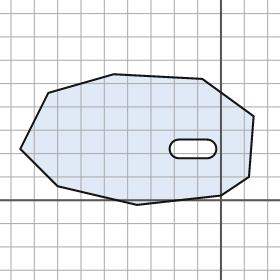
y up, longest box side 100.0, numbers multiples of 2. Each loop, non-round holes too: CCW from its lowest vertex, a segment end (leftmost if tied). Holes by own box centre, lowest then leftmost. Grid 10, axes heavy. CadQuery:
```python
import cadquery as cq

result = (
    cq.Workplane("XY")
    .moveTo(-36.0, -2.0)
    .lineTo(0.0, 2.0)
    .lineTo(12.0, 10.0)
    .lineTo(14.0, 36.0)
    .lineTo(-8.0, 52.0)
    .lineTo(-46.0, 54.0)
    .lineTo(-74.0, 46.0)
    .lineTo(-86.0, 22.0)
    .lineTo(-70.0, 6.0)
    .close()
    .moveTo(-18.0, 18.0)
    .lineTo(-6.0, 18.0)
    .threePointArc((-2.0, 22.0), (-6.0, 26.0))
    .lineTo(-18.0, 26.0)
    .threePointArc((-22.0, 22.0), (-18.0, 18.0))
    .close()
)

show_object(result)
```